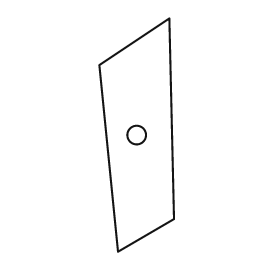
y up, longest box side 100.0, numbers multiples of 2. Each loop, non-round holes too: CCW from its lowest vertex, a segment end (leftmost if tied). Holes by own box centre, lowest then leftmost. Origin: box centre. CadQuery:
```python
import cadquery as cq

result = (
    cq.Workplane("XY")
    .moveTo(-8.0, -50.0)
    .lineTo(16.0, -36.0)
    .lineTo(14.0, 50.0)
    .lineTo(-16.0, 30.0)
    .close()
    .moveTo(0.0, 0.0)
    .circle(4.0)
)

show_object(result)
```